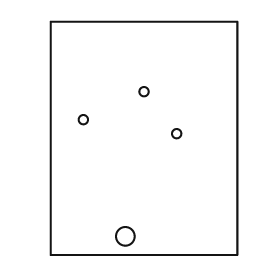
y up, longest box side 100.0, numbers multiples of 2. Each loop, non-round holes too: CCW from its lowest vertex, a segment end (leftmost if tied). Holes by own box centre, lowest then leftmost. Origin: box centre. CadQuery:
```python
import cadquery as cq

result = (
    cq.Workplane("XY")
    .moveTo(-40.0, -50.0)
    .lineTo(40.0, -50.0)
    .lineTo(40.0, 50.0)
    .lineTo(-40.0, 50.0)
    .close()
    .moveTo(-8.0, -42.0)
    .circle(4.0)
    .moveTo(14.0, 2.0)
    .circle(2.0)
    .moveTo(-26.0, 8.0)
    .circle(2.0)
    .moveTo(0.0, 20.0)
    .circle(2.0)
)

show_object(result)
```